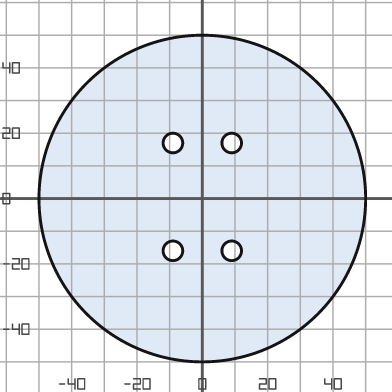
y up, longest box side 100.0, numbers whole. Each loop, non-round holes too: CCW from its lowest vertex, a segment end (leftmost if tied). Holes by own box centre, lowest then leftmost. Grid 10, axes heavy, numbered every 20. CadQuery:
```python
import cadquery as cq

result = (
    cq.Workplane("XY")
    .moveTo(0.0, 0.0)
    .circle(50.0)
    .moveTo(-9.0, -16.0)
    .circle(3.0)
    .moveTo(9.0, -16.0)
    .circle(3.0)
    .moveTo(-9.0, 17.0)
    .circle(3.0)
    .moveTo(9.0, 17.0)
    .circle(3.0)
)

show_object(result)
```